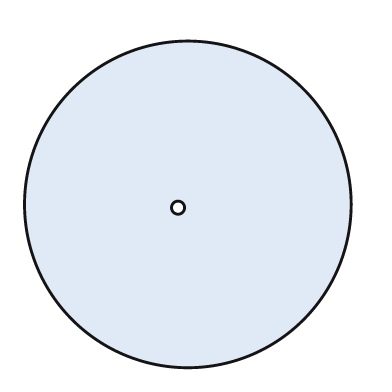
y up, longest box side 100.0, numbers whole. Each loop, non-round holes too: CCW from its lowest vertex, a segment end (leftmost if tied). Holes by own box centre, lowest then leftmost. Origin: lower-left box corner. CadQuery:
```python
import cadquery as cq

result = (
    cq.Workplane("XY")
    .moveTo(50.0, 50.0)
    .circle(50.0)
    .moveTo(47.0, 49.0)
    .circle(2.0)
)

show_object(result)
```